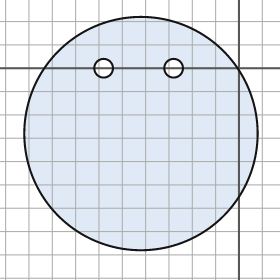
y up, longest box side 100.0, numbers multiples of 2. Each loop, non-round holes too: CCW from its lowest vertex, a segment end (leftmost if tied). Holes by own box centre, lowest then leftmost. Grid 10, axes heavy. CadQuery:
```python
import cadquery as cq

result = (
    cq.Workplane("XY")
    .moveTo(-42.0, -28.0)
    .circle(50.0)
    .moveTo(-58.0, 0.0)
    .circle(4.0)
    .moveTo(-28.0, 0.0)
    .circle(4.0)
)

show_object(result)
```